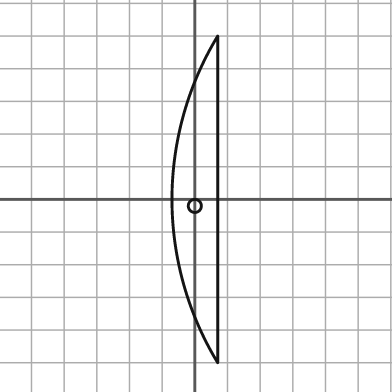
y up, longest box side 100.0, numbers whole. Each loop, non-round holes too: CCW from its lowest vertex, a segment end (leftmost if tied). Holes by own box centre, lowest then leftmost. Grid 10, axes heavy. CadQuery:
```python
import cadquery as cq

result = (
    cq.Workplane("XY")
    .moveTo(7.0, -50.0)
    .lineTo(7.0, 50.0)
    .threePointArc((-7.0, 0.0), (7.0, -50.0))
    .close()
    .moveTo(0.0, -2.0)
    .circle(2.0)
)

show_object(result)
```